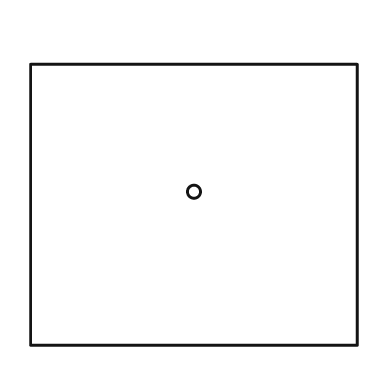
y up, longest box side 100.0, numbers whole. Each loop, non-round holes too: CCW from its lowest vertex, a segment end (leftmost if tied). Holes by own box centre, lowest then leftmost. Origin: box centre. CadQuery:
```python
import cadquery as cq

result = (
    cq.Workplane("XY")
    .moveTo(-50.0, -43.0)
    .lineTo(50.0, -43.0)
    .lineTo(50.0, 43.0)
    .lineTo(-50.0, 43.0)
    .close()
    .moveTo(0.0, 4.0)
    .circle(2.0)
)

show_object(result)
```